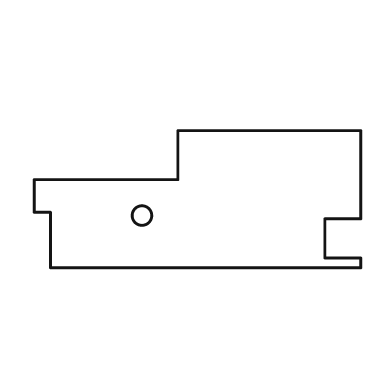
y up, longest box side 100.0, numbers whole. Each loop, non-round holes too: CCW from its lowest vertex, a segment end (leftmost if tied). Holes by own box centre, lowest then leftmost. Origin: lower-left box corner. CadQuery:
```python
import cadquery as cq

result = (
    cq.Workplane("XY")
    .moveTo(5.0, 0.0)
    .lineTo(100.0, 0.0)
    .lineTo(100.0, 3.0)
    .lineTo(89.0, 3.0)
    .lineTo(89.0, 15.0)
    .lineTo(100.0, 15.0)
    .lineTo(100.0, 42.0)
    .lineTo(44.0, 42.0)
    .lineTo(44.0, 27.0)
    .lineTo(0.0, 27.0)
    .lineTo(0.0, 17.0)
    .lineTo(5.0, 17.0)
    .close()
    .moveTo(33.0, 16.0)
    .circle(3.0)
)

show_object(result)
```